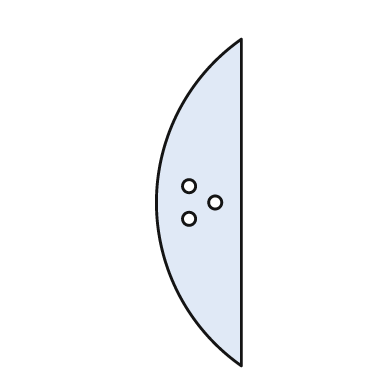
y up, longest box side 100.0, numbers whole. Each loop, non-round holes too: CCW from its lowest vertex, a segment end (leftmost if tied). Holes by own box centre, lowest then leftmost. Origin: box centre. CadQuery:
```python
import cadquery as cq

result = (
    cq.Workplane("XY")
    .moveTo(13.0, -50.0)
    .lineTo(13.0, 50.0)
    .threePointArc((-13.0, 0.0), (13.0, -50.0))
    .close()
    .moveTo(-3.0, -5.0)
    .circle(2.0)
    .moveTo(5.0, 0.0)
    .circle(2.0)
    .moveTo(-3.0, 5.0)
    .circle(2.0)
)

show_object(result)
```